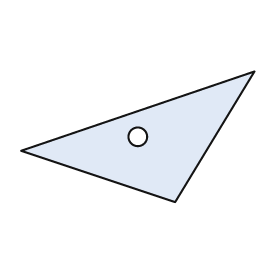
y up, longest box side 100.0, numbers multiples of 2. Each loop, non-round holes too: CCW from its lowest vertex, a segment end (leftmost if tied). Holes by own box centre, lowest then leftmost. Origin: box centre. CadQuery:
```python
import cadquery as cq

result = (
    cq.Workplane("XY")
    .moveTo(16.0, -28.0)
    .lineTo(50.0, 28.0)
    .lineTo(-50.0, -6.0)
    .close()
    .moveTo(0.0, 0.0)
    .circle(4.0)
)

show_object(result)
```